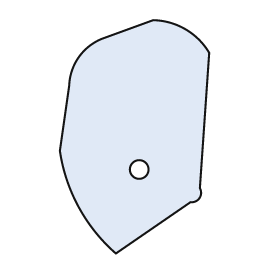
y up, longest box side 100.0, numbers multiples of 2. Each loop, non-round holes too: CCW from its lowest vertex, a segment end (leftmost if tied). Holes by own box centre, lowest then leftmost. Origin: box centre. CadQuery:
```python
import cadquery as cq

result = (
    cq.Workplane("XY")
    .moveTo(-8.0, -50.0)
    .lineTo(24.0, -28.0)
    .threePointArc((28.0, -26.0), (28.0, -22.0))
    .lineTo(32.0, 36.0)
    .threePointArc((22.0, 46.0), (8.0, 50.0))
    .lineTo(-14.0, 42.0)
    .threePointArc((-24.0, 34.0), (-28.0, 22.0))
    .lineTo(-32.0, -6.0)
    .threePointArc((-24.0, -30.0), (-8.0, -50.0))
    .close()
    .moveTo(2.0, -14.0)
    .circle(4.0)
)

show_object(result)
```